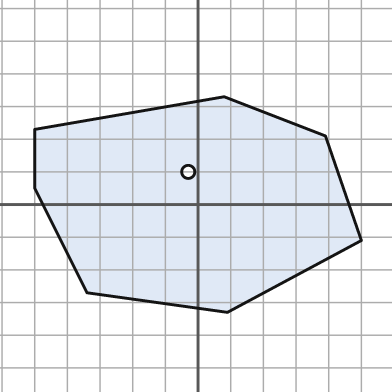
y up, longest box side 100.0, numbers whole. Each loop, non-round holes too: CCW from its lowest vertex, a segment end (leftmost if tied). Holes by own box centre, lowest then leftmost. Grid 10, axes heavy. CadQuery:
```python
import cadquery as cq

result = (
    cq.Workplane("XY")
    .moveTo(9.0, -33.0)
    .lineTo(50.0, -11.0)
    .lineTo(39.0, 21.0)
    .lineTo(8.0, 33.0)
    .lineTo(-50.0, 23.0)
    .lineTo(-50.0, 5.0)
    .lineTo(-34.0, -27.0)
    .close()
    .moveTo(-3.0, 10.0)
    .circle(2.0)
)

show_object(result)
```